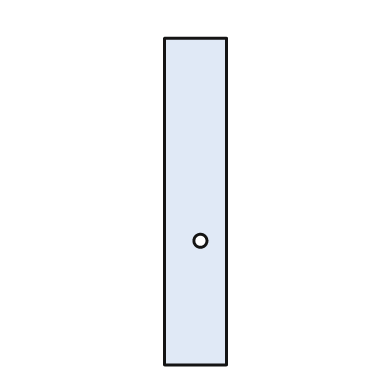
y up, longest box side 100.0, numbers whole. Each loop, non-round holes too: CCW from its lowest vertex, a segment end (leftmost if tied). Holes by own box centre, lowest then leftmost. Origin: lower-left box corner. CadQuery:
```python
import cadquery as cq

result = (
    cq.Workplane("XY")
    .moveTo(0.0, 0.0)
    .lineTo(19.0, 0.0)
    .lineTo(19.0, 100.0)
    .lineTo(0.0, 100.0)
    .close()
    .moveTo(11.0, 38.0)
    .circle(2.0)
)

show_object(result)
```